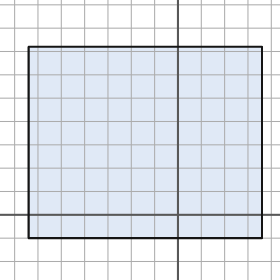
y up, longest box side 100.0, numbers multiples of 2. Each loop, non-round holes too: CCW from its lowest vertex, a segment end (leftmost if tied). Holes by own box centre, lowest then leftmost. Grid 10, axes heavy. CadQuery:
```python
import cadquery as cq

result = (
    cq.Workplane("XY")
    .moveTo(-64.0, -10.0)
    .lineTo(36.0, -10.0)
    .lineTo(36.0, 72.0)
    .lineTo(-64.0, 72.0)
    .close()
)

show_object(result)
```